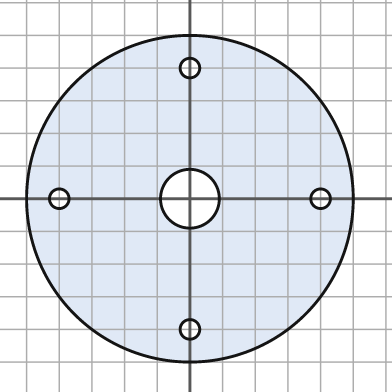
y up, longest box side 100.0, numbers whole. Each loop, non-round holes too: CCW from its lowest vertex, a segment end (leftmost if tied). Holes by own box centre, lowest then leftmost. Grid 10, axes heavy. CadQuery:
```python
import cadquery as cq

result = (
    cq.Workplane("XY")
    .moveTo(0.0, 0.0)
    .circle(50.0)
    .moveTo(0.0, -40.0)
    .circle(3.0)
    .moveTo(-40.0, 0.0)
    .circle(3.0)
    .moveTo(0.0, 0.0)
    .circle(9.0)
    .moveTo(40.0, 0.0)
    .circle(3.0)
    .moveTo(0.0, 40.0)
    .circle(3.0)
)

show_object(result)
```